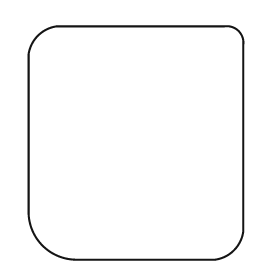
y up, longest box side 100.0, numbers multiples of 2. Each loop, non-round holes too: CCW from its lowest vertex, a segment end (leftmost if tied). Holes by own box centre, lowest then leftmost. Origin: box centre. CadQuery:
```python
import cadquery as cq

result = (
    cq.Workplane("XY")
    .moveTo(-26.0, -50.0)
    .lineTo(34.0, -50.0)
    .threePointArc((42.0, -46.0), (46.0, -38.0))
    .lineTo(46.0, 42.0)
    .threePointArc((44.0, 48.0), (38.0, 50.0))
    .lineTo(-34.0, 50.0)
    .threePointArc((-42.0, 46.0), (-46.0, 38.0))
    .lineTo(-46.0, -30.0)
    .threePointArc((-40.0, -44.0), (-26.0, -50.0))
    .close()
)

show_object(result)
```